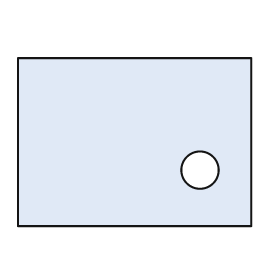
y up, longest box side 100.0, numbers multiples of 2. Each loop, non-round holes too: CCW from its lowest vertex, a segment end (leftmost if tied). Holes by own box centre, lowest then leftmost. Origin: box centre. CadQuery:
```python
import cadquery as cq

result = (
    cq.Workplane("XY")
    .moveTo(-50.0, -36.0)
    .lineTo(50.0, -36.0)
    .lineTo(50.0, 36.0)
    .lineTo(-50.0, 36.0)
    .close()
    .moveTo(28.0, -12.0)
    .circle(8.0)
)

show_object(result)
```